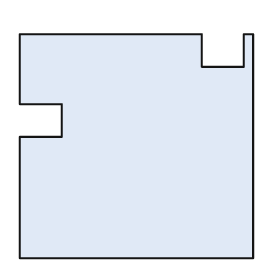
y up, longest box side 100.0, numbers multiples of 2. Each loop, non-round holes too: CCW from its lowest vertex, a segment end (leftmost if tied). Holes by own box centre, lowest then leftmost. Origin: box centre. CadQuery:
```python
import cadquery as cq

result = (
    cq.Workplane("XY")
    .moveTo(-50.0, -48.0)
    .lineTo(50.0, -48.0)
    .lineTo(50.0, 48.0)
    .lineTo(46.0, 48.0)
    .lineTo(46.0, 34.0)
    .lineTo(28.0, 34.0)
    .lineTo(28.0, 48.0)
    .lineTo(-50.0, 48.0)
    .lineTo(-50.0, 18.0)
    .lineTo(-32.0, 18.0)
    .lineTo(-32.0, 4.0)
    .lineTo(-50.0, 4.0)
    .close()
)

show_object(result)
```